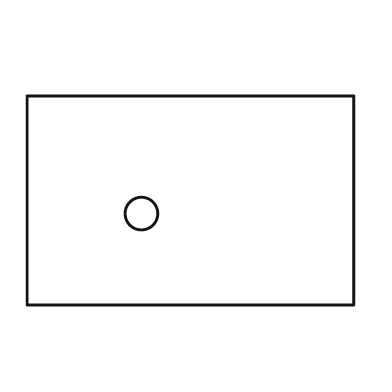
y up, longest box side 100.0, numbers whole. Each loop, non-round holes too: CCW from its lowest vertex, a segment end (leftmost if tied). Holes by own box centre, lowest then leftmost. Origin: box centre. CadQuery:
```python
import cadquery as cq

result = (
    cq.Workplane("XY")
    .moveTo(-50.0, -32.0)
    .lineTo(50.0, -32.0)
    .lineTo(50.0, 32.0)
    .lineTo(-50.0, 32.0)
    .close()
    .moveTo(-15.0, -4.0)
    .circle(5.0)
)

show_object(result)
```